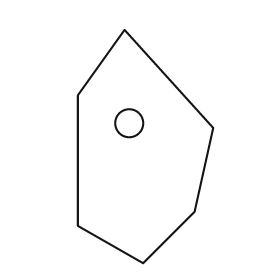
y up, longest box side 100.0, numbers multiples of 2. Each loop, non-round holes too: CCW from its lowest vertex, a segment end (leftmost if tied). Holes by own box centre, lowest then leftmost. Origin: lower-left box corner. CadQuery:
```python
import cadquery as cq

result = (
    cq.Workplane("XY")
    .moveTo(28.0, 0.0)
    .lineTo(50.0, 22.0)
    .lineTo(58.0, 58.0)
    .lineTo(20.0, 100.0)
    .lineTo(0.0, 72.0)
    .lineTo(0.0, 16.0)
    .close()
    .moveTo(22.0, 60.0)
    .circle(6.0)
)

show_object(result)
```